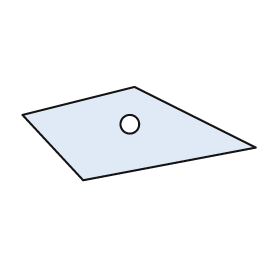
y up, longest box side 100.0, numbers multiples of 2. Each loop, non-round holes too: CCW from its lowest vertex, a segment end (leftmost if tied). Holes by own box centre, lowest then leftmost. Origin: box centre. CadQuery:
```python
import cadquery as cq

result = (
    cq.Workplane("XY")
    .moveTo(-24.0, -20.0)
    .lineTo(50.0, -6.0)
    .lineTo(-2.0, 20.0)
    .lineTo(-50.0, 8.0)
    .close()
    .moveTo(-4.0, 4.0)
    .circle(4.0)
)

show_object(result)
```